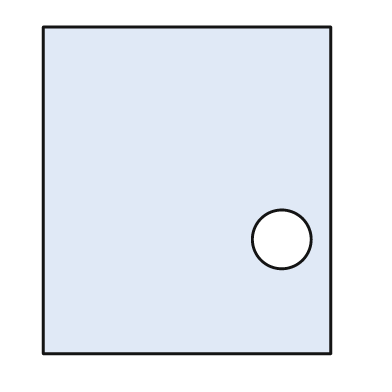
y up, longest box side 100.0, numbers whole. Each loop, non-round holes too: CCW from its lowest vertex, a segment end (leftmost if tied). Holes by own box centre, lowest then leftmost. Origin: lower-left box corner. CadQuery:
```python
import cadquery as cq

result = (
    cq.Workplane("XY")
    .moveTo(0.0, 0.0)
    .lineTo(88.0, 0.0)
    .lineTo(88.0, 100.0)
    .lineTo(0.0, 100.0)
    .close()
    .moveTo(73.0, 35.0)
    .circle(9.0)
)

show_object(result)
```